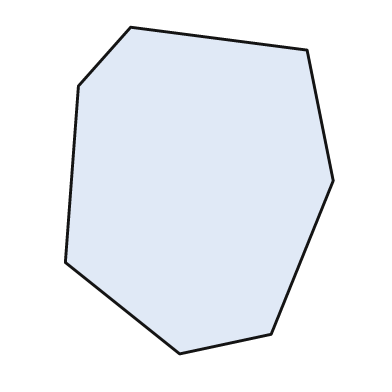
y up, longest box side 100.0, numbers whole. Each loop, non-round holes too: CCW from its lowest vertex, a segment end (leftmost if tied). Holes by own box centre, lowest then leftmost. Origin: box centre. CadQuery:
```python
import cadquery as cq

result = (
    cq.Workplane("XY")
    .moveTo(-6.0, -50.0)
    .lineTo(22.0, -44.0)
    .lineTo(41.0, 3.0)
    .lineTo(33.0, 43.0)
    .lineTo(-21.0, 50.0)
    .lineTo(-37.0, 32.0)
    .lineTo(-41.0, -22.0)
    .close()
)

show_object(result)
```